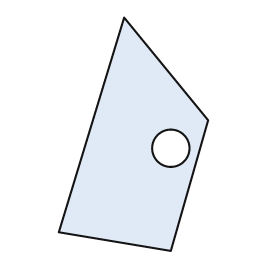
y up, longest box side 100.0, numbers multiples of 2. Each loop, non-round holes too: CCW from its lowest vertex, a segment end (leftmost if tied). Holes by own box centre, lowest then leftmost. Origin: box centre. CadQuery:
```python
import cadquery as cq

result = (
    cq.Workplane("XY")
    .moveTo(16.0, -50.0)
    .lineTo(32.0, 6.0)
    .lineTo(-4.0, 50.0)
    .lineTo(-32.0, -42.0)
    .close()
    .moveTo(16.0, -6.0)
    .circle(8.0)
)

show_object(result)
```